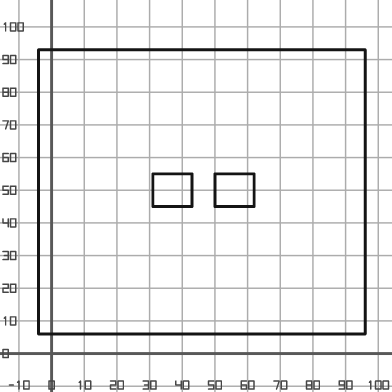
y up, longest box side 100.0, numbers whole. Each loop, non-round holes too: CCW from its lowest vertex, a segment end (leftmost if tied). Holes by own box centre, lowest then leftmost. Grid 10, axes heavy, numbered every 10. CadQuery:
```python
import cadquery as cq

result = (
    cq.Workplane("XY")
    .moveTo(-4.0, 6.0)
    .lineTo(96.0, 6.0)
    .lineTo(96.0, 93.0)
    .lineTo(-4.0, 93.0)
    .close()
    .moveTo(31.0, 45.0)
    .lineTo(43.0, 45.0)
    .lineTo(43.0, 55.0)
    .lineTo(31.0, 55.0)
    .close()
    .moveTo(50.0, 45.0)
    .lineTo(62.0, 45.0)
    .lineTo(62.0, 55.0)
    .lineTo(50.0, 55.0)
    .close()
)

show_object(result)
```